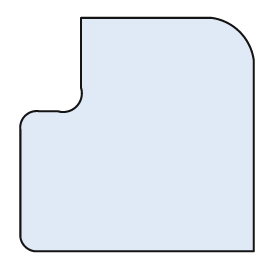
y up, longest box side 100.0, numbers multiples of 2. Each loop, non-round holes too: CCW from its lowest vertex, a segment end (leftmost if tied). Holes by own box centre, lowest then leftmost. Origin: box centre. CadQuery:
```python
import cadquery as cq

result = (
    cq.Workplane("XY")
    .moveTo(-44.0, -50.0)
    .lineTo(50.0, -50.0)
    .lineTo(50.0, 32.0)
    .threePointArc((44.0, 44.0), (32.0, 50.0))
    .lineTo(-24.0, 50.0)
    .lineTo(-24.0, 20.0)
    .threePointArc((-26.0, 12.0), (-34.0, 10.0))
    .lineTo(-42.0, 10.0)
    .threePointArc((-48.0, 8.0), (-50.0, 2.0))
    .lineTo(-50.0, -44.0)
    .threePointArc((-48.0, -48.0), (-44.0, -50.0))
    .close()
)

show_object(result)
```